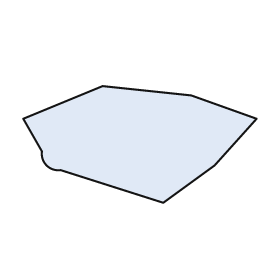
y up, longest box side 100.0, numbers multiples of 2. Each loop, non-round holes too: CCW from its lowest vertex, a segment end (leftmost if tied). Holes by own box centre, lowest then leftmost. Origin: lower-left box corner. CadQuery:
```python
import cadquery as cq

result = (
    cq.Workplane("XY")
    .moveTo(60.0, 0.0)
    .lineTo(82.0, 16.0)
    .lineTo(100.0, 36.0)
    .lineTo(72.0, 46.0)
    .lineTo(34.0, 50.0)
    .lineTo(0.0, 36.0)
    .lineTo(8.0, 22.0)
    .threePointArc((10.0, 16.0), (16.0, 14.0))
    .close()
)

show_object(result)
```